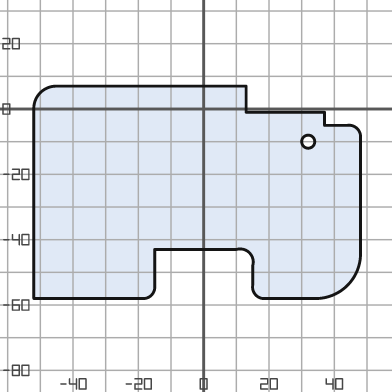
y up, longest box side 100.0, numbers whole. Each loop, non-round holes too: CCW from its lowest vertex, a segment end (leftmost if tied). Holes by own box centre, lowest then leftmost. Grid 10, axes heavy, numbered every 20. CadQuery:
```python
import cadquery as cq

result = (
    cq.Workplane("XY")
    .moveTo(-52.0, -58.0)
    .lineTo(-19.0, -58.0)
    .threePointArc((-16.0, -57.0), (-15.0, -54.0))
    .lineTo(-15.0, -43.0)
    .lineTo(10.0, -43.0)
    .threePointArc((14.0, -44.0), (15.0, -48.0))
    .lineTo(15.0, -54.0)
    .threePointArc((16.0, -57.0), (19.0, -58.0))
    .lineTo(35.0, -58.0)
    .threePointArc((44.0, -54.0), (48.0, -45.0))
    .lineTo(48.0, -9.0)
    .threePointArc((47.0, -6.0), (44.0, -5.0))
    .lineTo(37.0, -5.0)
    .lineTo(37.0, -1.0)
    .lineTo(13.0, -1.0)
    .lineTo(13.0, 7.0)
    .lineTo(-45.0, 7.0)
    .threePointArc((-50.0, 5.0), (-52.0, 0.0))
    .close()
    .moveTo(32.0, -10.0)
    .circle(2.0)
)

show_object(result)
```